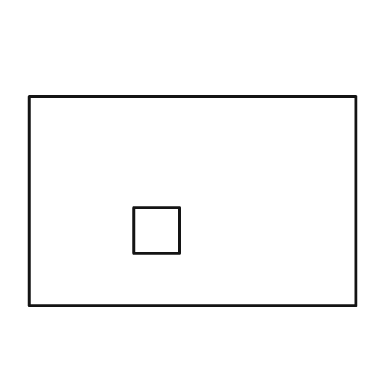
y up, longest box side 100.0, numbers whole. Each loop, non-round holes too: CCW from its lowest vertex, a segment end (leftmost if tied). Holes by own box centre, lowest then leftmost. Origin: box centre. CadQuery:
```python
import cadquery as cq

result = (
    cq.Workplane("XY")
    .moveTo(-50.0, -32.0)
    .lineTo(50.0, -32.0)
    .lineTo(50.0, 32.0)
    .lineTo(-50.0, 32.0)
    .close()
    .moveTo(-18.0, -16.0)
    .lineTo(-4.0, -16.0)
    .lineTo(-4.0, -2.0)
    .lineTo(-18.0, -2.0)
    .close()
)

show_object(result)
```